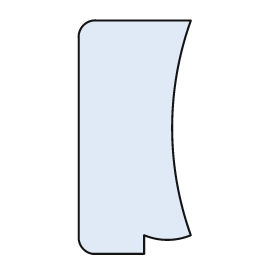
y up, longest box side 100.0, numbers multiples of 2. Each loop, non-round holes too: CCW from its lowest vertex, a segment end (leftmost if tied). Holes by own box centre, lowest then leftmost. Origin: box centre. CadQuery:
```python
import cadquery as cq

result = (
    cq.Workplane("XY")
    .moveTo(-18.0, -50.0)
    .lineTo(4.0, -50.0)
    .lineTo(4.0, -42.0)
    .threePointArc((14.0, -44.0), (24.0, -42.0))
    .threePointArc((16.0, 4.0), (24.0, 50.0))
    .lineTo(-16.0, 50.0)
    .threePointArc((-22.0, 48.0), (-24.0, 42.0))
    .lineTo(-24.0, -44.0)
    .threePointArc((-22.0, -48.0), (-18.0, -50.0))
    .close()
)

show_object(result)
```